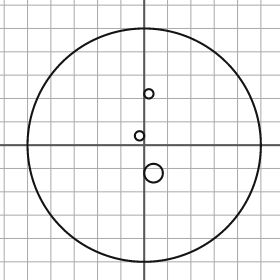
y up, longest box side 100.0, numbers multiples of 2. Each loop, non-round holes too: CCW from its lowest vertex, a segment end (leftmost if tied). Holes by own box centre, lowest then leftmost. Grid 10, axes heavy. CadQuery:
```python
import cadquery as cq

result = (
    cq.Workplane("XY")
    .moveTo(0.0, 0.0)
    .circle(50.0)
    .moveTo(4.0, -12.0)
    .circle(4.0)
    .moveTo(-2.0, 4.0)
    .circle(2.0)
    .moveTo(2.0, 22.0)
    .circle(2.0)
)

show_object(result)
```